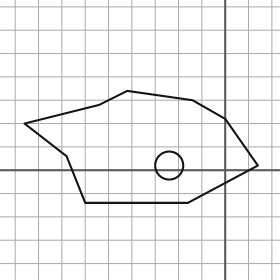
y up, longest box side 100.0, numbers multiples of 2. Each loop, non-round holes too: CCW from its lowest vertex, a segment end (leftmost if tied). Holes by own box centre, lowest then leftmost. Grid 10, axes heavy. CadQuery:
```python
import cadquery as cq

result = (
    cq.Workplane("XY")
    .moveTo(-60.0, -14.0)
    .lineTo(-16.0, -14.0)
    .lineTo(14.0, 2.0)
    .lineTo(0.0, 22.0)
    .lineTo(-14.0, 30.0)
    .lineTo(-42.0, 34.0)
    .lineTo(-54.0, 28.0)
    .lineTo(-86.0, 20.0)
    .lineTo(-68.0, 6.0)
    .close()
    .moveTo(-24.0, 2.0)
    .circle(6.0)
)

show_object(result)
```